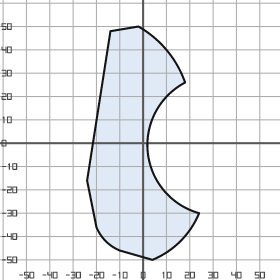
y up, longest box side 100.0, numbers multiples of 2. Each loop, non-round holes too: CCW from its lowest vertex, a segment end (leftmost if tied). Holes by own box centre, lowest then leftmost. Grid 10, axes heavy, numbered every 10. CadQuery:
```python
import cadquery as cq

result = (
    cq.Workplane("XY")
    .moveTo(4.0, -50.0)
    .threePointArc((16.0, -42.0), (24.0, -30.0))
    .threePointArc((2.0, -4.0), (18.0, 26.0))
    .threePointArc((10.0, 40.0), (-2.0, 50.0))
    .lineTo(-14.0, 48.0)
    .lineTo(-24.0, -16.0)
    .lineTo(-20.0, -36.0)
    .threePointArc((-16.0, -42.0), (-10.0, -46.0))
    .close()
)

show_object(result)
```